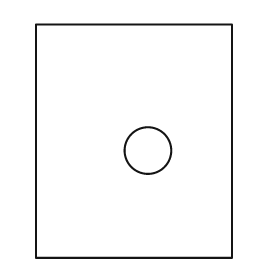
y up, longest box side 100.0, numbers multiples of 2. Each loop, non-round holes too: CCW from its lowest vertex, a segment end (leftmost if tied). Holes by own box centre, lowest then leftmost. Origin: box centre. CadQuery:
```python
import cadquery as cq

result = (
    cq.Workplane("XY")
    .moveTo(-42.0, -50.0)
    .lineTo(42.0, -50.0)
    .lineTo(42.0, 50.0)
    .lineTo(-42.0, 50.0)
    .close()
    .moveTo(6.0, -4.0)
    .circle(10.0)
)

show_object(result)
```